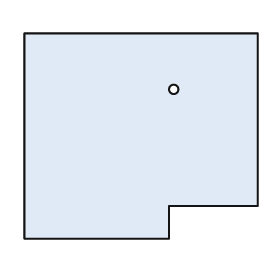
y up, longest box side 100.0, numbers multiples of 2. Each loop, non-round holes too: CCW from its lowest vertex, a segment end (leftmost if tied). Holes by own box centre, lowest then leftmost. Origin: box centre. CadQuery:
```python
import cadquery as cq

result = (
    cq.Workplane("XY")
    .moveTo(-50.0, -44.0)
    .lineTo(12.0, -44.0)
    .lineTo(12.0, -30.0)
    .lineTo(50.0, -30.0)
    .lineTo(50.0, 44.0)
    .lineTo(-50.0, 44.0)
    .close()
    .moveTo(14.0, 20.0)
    .circle(2.0)
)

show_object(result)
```